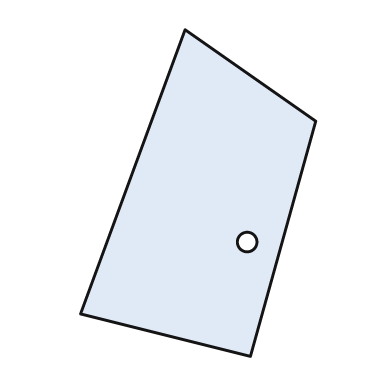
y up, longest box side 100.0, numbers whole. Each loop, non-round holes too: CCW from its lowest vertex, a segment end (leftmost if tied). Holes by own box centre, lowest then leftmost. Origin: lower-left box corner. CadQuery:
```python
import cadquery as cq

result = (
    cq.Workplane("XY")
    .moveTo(52.0, 0.0)
    .lineTo(72.0, 72.0)
    .lineTo(32.0, 100.0)
    .lineTo(0.0, 13.0)
    .close()
    .moveTo(51.0, 35.0)
    .circle(3.0)
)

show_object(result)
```